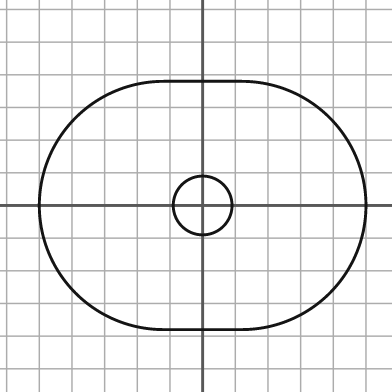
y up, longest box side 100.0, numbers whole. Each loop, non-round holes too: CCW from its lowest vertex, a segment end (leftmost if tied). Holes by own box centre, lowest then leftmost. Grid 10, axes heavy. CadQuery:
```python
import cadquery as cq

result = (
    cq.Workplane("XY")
    .moveTo(-12.0, -38.0)
    .lineTo(12.0, -38.0)
    .threePointArc((50.0, 0.0), (12.0, 38.0))
    .lineTo(-12.0, 38.0)
    .threePointArc((-50.0, 0.0), (-12.0, -38.0))
    .close()
    .moveTo(0.0, 0.0)
    .circle(9.0)
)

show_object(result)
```